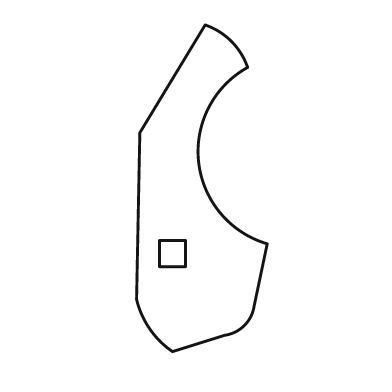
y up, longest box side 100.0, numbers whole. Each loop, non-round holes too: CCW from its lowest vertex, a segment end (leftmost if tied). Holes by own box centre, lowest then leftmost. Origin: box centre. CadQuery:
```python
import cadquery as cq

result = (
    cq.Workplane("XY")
    .moveTo(-9.0, -50.0)
    .lineTo(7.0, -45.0)
    .threePointArc((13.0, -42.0), (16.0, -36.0))
    .lineTo(20.0, -17.0)
    .threePointArc((-1.0, 8.0), (14.0, 37.0))
    .threePointArc((9.0, 45.0), (1.0, 50.0))
    .lineTo(-19.0, 17.0)
    .lineTo(-20.0, -34.0)
    .threePointArc((-16.0, -43.0), (-9.0, -50.0))
    .close()
    .moveTo(-13.0, -24.0)
    .lineTo(-5.0, -24.0)
    .lineTo(-5.0, -16.0)
    .lineTo(-13.0, -16.0)
    .close()
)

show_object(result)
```